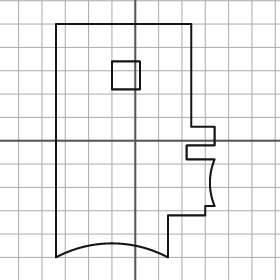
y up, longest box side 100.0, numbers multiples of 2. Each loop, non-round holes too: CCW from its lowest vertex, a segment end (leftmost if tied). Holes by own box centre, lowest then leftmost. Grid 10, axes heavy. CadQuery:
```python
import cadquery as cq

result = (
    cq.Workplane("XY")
    .moveTo(-34.0, -50.0)
    .threePointArc((-10.0, -44.0), (14.0, -50.0))
    .lineTo(14.0, -32.0)
    .lineTo(30.0, -32.0)
    .lineTo(30.0, -28.0)
    .lineTo(34.0, -28.0)
    .threePointArc((32.0, -18.0), (34.0, -8.0))
    .lineTo(22.0, -8.0)
    .lineTo(22.0, -2.0)
    .lineTo(34.0, -2.0)
    .lineTo(34.0, 6.0)
    .lineTo(24.0, 6.0)
    .lineTo(24.0, 50.0)
    .lineTo(-34.0, 50.0)
    .close()
    .moveTo(-10.0, 22.0)
    .lineTo(2.0, 22.0)
    .lineTo(2.0, 34.0)
    .lineTo(-10.0, 34.0)
    .close()
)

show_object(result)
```